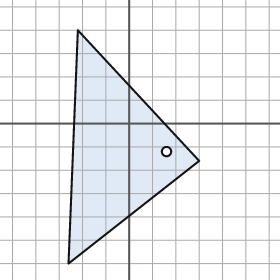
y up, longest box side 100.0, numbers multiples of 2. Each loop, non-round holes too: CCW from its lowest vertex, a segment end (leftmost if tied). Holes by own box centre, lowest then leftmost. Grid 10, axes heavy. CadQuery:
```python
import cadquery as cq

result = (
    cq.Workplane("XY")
    .moveTo(-26.0, -60.0)
    .lineTo(30.0, -16.0)
    .lineTo(-22.0, 40.0)
    .close()
    .moveTo(16.0, -12.0)
    .circle(2.0)
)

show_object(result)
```